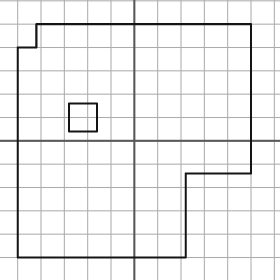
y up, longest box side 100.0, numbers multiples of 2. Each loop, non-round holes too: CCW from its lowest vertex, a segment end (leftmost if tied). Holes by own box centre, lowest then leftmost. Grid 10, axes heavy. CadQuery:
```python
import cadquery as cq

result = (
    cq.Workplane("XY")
    .moveTo(-50.0, -50.0)
    .lineTo(22.0, -50.0)
    .lineTo(22.0, -14.0)
    .lineTo(50.0, -14.0)
    .lineTo(50.0, 50.0)
    .lineTo(-42.0, 50.0)
    .lineTo(-42.0, 40.0)
    .lineTo(-50.0, 40.0)
    .close()
    .moveTo(-28.0, 4.0)
    .lineTo(-16.0, 4.0)
    .lineTo(-16.0, 16.0)
    .lineTo(-28.0, 16.0)
    .close()
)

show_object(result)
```